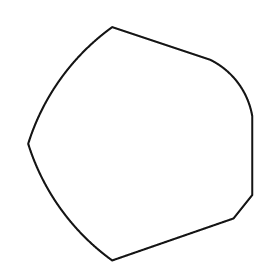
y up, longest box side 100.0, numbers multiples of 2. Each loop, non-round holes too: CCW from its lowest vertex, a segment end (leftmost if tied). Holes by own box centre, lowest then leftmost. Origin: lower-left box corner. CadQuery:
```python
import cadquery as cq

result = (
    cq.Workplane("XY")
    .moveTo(36.0, 0.0)
    .lineTo(88.0, 18.0)
    .lineTo(96.0, 28.0)
    .lineTo(96.0, 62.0)
    .threePointArc((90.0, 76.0), (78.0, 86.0))
    .lineTo(36.0, 100.0)
    .threePointArc((14.0, 78.0), (0.0, 50.0))
    .threePointArc((14.0, 22.0), (36.0, 0.0))
    .close()
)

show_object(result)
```